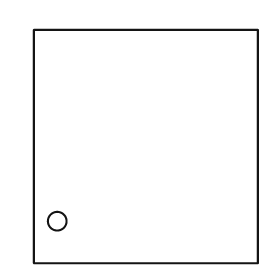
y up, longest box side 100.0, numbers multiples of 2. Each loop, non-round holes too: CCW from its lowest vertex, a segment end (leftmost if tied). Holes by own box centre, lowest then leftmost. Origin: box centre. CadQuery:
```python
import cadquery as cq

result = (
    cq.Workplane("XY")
    .moveTo(-48.0, -50.0)
    .lineTo(48.0, -50.0)
    .lineTo(48.0, 50.0)
    .lineTo(-48.0, 50.0)
    .close()
    .moveTo(-38.0, -32.0)
    .circle(4.0)
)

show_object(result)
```